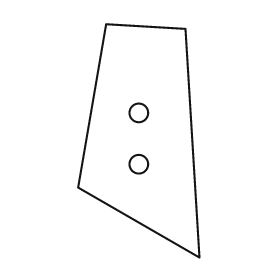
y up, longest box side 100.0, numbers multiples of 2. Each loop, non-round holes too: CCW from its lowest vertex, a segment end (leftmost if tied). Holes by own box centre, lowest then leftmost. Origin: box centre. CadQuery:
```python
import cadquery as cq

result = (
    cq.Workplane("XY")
    .moveTo(26.0, -50.0)
    .lineTo(20.0, 48.0)
    .lineTo(-14.0, 50.0)
    .lineTo(-26.0, -20.0)
    .close()
    .moveTo(0.0, -10.0)
    .circle(4.0)
    .moveTo(0.0, 12.0)
    .circle(4.0)
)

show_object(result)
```